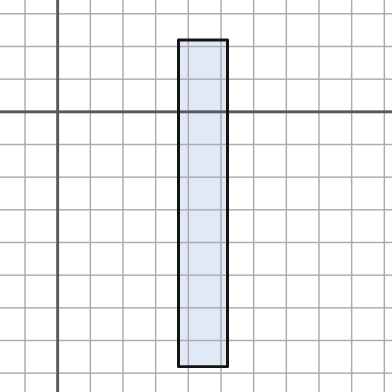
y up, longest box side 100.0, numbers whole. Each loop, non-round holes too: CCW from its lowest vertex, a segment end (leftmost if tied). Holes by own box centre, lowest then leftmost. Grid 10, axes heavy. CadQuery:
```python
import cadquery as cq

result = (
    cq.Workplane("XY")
    .moveTo(37.0, -78.0)
    .lineTo(52.0, -78.0)
    .lineTo(52.0, 22.0)
    .lineTo(37.0, 22.0)
    .close()
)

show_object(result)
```